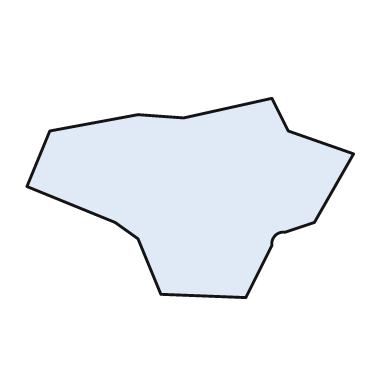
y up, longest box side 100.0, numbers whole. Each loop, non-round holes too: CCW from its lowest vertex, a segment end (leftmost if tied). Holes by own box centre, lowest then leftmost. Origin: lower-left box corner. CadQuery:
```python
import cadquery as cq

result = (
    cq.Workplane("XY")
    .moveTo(67.0, 0.0)
    .lineTo(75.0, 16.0)
    .threePointArc((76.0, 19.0), (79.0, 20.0))
    .lineTo(88.0, 23.0)
    .lineTo(100.0, 44.0)
    .lineTo(80.0, 51.0)
    .lineTo(75.0, 61.0)
    .lineTo(48.0, 55.0)
    .lineTo(34.0, 56.0)
    .lineTo(7.0, 51.0)
    .lineTo(0.0, 34.0)
    .lineTo(27.0, 23.0)
    .lineTo(34.0, 18.0)
    .lineTo(41.0, 1.0)
    .close()
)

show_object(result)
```